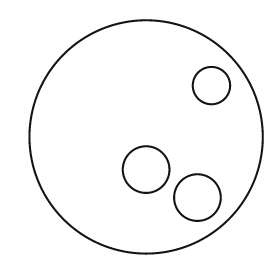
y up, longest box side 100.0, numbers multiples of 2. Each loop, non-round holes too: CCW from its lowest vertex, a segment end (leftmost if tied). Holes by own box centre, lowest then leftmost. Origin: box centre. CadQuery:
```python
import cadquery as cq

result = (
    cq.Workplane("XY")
    .moveTo(0.0, 0.0)
    .circle(50.0)
    .moveTo(22.0, -26.0)
    .circle(10.0)
    .moveTo(0.0, -14.0)
    .circle(10.0)
    .moveTo(28.0, 22.0)
    .circle(8.0)
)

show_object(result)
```